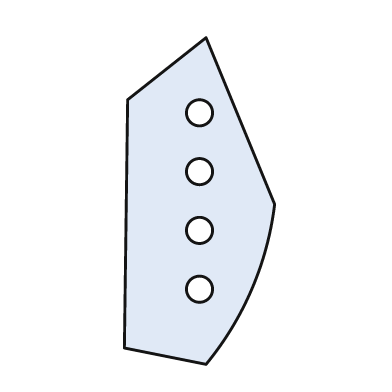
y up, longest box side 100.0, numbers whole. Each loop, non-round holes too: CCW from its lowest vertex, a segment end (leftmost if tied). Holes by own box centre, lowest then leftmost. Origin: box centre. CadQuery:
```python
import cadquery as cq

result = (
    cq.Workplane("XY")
    .moveTo(2.0, -50.0)
    .threePointArc((16.0, -27.0), (23.0, -1.0))
    .lineTo(2.0, 50.0)
    .lineTo(-22.0, 31.0)
    .lineTo(-23.0, -45.0)
    .close()
    .moveTo(0.0, -27.0)
    .circle(4.0)
    .moveTo(0.0, -9.0)
    .circle(4.0)
    .moveTo(0.0, 9.0)
    .circle(4.0)
    .moveTo(0.0, 27.0)
    .circle(4.0)
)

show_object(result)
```